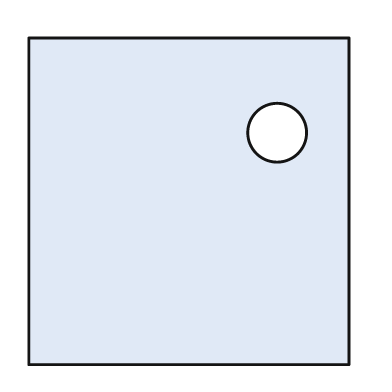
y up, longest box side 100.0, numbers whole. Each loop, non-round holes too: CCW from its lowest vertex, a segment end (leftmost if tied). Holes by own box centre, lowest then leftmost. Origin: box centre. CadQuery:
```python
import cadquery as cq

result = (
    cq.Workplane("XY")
    .moveTo(-49.0, -50.0)
    .lineTo(49.0, -50.0)
    .lineTo(49.0, 50.0)
    .lineTo(-49.0, 50.0)
    .close()
    .moveTo(27.0, 21.0)
    .circle(9.0)
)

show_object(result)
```